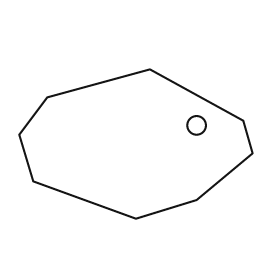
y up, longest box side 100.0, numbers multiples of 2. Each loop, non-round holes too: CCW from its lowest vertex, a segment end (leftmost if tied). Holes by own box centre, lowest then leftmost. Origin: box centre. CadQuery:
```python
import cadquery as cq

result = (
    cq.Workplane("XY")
    .moveTo(0.0, -32.0)
    .lineTo(26.0, -24.0)
    .lineTo(50.0, -4.0)
    .lineTo(46.0, 10.0)
    .lineTo(6.0, 32.0)
    .lineTo(-38.0, 20.0)
    .lineTo(-50.0, 4.0)
    .lineTo(-44.0, -16.0)
    .close()
    .moveTo(26.0, 8.0)
    .circle(4.0)
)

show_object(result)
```